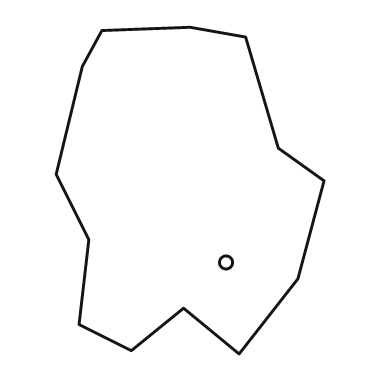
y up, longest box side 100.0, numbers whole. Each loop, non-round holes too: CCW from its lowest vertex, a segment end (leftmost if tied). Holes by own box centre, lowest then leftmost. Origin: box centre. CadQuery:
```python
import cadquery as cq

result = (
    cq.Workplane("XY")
    .moveTo(15.0, -50.0)
    .lineTo(33.0, -27.0)
    .lineTo(41.0, 3.0)
    .lineTo(27.0, 13.0)
    .lineTo(17.0, 47.0)
    .lineTo(0.0, 50.0)
    .lineTo(-27.0, 49.0)
    .lineTo(-33.0, 38.0)
    .lineTo(-41.0, 5.0)
    .lineTo(-31.0, -15.0)
    .lineTo(-34.0, -41.0)
    .lineTo(-18.0, -49.0)
    .lineTo(-2.0, -36.0)
    .close()
    .moveTo(11.0, -22.0)
    .circle(2.0)
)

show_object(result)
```